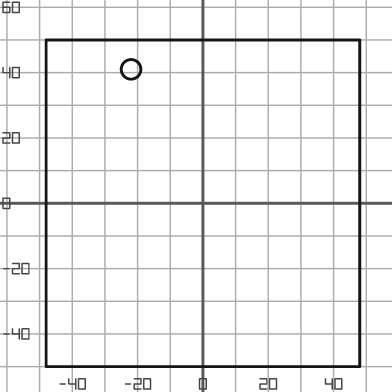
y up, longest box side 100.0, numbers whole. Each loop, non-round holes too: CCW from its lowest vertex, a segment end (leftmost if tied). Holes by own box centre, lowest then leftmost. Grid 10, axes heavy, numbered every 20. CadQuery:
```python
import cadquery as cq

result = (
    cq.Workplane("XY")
    .moveTo(-48.0, -50.0)
    .lineTo(48.0, -50.0)
    .lineTo(48.0, 50.0)
    .lineTo(-48.0, 50.0)
    .close()
    .moveTo(-22.0, 41.0)
    .circle(3.0)
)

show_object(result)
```